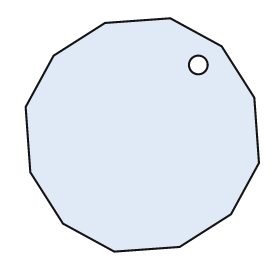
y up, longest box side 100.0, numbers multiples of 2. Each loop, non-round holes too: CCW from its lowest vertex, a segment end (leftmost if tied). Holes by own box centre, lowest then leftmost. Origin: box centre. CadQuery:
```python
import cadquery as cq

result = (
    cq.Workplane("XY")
    .moveTo(-12.0, -50.0)
    .lineTo(16.0, -48.0)
    .lineTo(38.0, -34.0)
    .lineTo(50.0, -12.0)
    .lineTo(48.0, 16.0)
    .lineTo(34.0, 38.0)
    .lineTo(12.0, 50.0)
    .lineTo(-16.0, 48.0)
    .lineTo(-38.0, 34.0)
    .lineTo(-50.0, 12.0)
    .lineTo(-48.0, -16.0)
    .lineTo(-34.0, -38.0)
    .close()
    .moveTo(24.0, 30.0)
    .circle(4.0)
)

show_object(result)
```